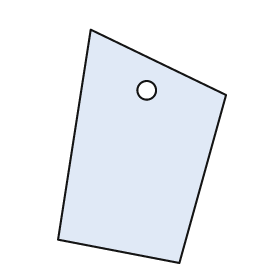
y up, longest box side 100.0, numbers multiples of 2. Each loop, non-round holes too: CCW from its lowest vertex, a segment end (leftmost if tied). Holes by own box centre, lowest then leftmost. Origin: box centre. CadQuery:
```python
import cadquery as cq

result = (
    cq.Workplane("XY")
    .moveTo(16.0, -50.0)
    .lineTo(36.0, 22.0)
    .lineTo(-22.0, 50.0)
    .lineTo(-36.0, -40.0)
    .close()
    .moveTo(2.0, 24.0)
    .circle(4.0)
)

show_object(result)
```